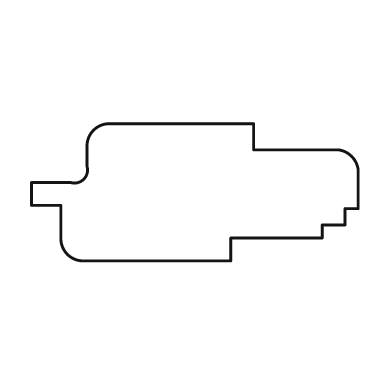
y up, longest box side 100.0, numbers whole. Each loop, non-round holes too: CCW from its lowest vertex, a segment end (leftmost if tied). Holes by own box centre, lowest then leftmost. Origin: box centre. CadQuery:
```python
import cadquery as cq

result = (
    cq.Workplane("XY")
    .moveTo(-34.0, -21.0)
    .lineTo(11.0, -21.0)
    .lineTo(11.0, -14.0)
    .lineTo(39.0, -14.0)
    .lineTo(39.0, -10.0)
    .lineTo(46.0, -10.0)
    .lineTo(46.0, -5.0)
    .lineTo(50.0, -5.0)
    .lineTo(50.0, 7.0)
    .threePointArc((48.0, 11.0), (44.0, 13.0))
    .lineTo(18.0, 13.0)
    .lineTo(18.0, 21.0)
    .lineTo(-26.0, 21.0)
    .threePointArc((-31.0, 19.0), (-33.0, 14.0))
    .lineTo(-33.0, 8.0)
    .threePointArc((-34.0, 4.0), (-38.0, 3.0))
    .lineTo(-50.0, 3.0)
    .lineTo(-50.0, -4.0)
    .lineTo(-41.0, -4.0)
    .lineTo(-41.0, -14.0)
    .threePointArc((-39.0, -19.0), (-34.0, -21.0))
    .close()
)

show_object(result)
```